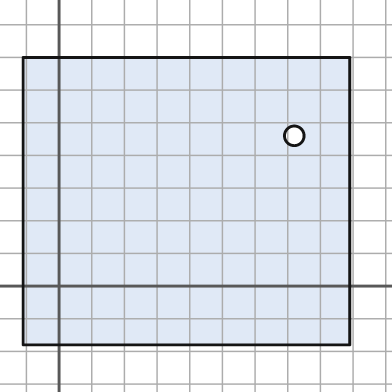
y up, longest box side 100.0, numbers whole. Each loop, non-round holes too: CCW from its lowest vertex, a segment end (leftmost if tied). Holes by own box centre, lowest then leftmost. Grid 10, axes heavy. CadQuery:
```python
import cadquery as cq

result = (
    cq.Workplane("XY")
    .moveTo(-11.0, -18.0)
    .lineTo(89.0, -18.0)
    .lineTo(89.0, 70.0)
    .lineTo(-11.0, 70.0)
    .close()
    .moveTo(72.0, 46.0)
    .circle(3.0)
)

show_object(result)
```